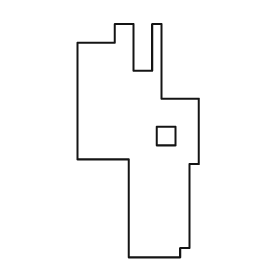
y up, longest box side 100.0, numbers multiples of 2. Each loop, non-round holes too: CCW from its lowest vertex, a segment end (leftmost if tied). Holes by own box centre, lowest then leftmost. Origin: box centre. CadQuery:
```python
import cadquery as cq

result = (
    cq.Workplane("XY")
    .moveTo(-4.0, -50.0)
    .lineTo(18.0, -50.0)
    .lineTo(18.0, -46.0)
    .lineTo(22.0, -46.0)
    .lineTo(22.0, -10.0)
    .lineTo(26.0, -10.0)
    .lineTo(26.0, 18.0)
    .lineTo(10.0, 18.0)
    .lineTo(10.0, 50.0)
    .lineTo(6.0, 50.0)
    .lineTo(6.0, 30.0)
    .lineTo(-2.0, 30.0)
    .lineTo(-2.0, 50.0)
    .lineTo(-10.0, 50.0)
    .lineTo(-10.0, 42.0)
    .lineTo(-26.0, 42.0)
    .lineTo(-26.0, -8.0)
    .lineTo(-4.0, -8.0)
    .close()
    .moveTo(8.0, -2.0)
    .lineTo(16.0, -2.0)
    .lineTo(16.0, 6.0)
    .lineTo(8.0, 6.0)
    .close()
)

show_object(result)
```